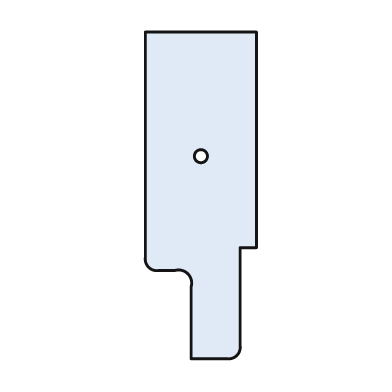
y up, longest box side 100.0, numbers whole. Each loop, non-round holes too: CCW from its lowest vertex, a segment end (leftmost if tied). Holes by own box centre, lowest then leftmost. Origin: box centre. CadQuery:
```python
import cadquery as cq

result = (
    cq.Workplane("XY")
    .moveTo(-3.0, -50.0)
    .lineTo(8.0, -50.0)
    .threePointArc((11.0, -49.0), (12.0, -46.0))
    .lineTo(12.0, -16.0)
    .lineTo(17.0, -16.0)
    .lineTo(17.0, 50.0)
    .lineTo(-17.0, 50.0)
    .lineTo(-17.0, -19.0)
    .threePointArc((-16.0, -22.0), (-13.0, -23.0))
    .lineTo(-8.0, -23.0)
    .threePointArc((-4.0, -24.0), (-3.0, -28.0))
    .close()
    .moveTo(0.0, 12.0)
    .circle(2.0)
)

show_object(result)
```